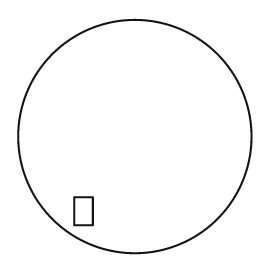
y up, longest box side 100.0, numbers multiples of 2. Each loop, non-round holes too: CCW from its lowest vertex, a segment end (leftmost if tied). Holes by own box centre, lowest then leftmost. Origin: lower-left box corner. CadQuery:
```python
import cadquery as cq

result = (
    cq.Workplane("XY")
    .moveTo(50.0, 50.0)
    .circle(50.0)
    .moveTo(24.0, 12.0)
    .lineTo(32.0, 12.0)
    .lineTo(32.0, 24.0)
    .lineTo(24.0, 24.0)
    .close()
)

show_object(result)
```